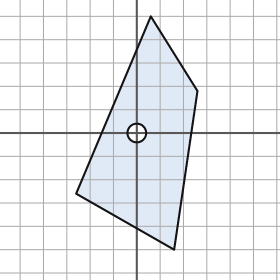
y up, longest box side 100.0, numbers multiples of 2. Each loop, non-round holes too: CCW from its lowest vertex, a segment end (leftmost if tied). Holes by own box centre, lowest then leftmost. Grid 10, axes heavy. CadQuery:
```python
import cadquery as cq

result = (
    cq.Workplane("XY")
    .moveTo(16.0, -50.0)
    .lineTo(26.0, 18.0)
    .lineTo(6.0, 50.0)
    .lineTo(-26.0, -26.0)
    .close()
    .moveTo(0.0, 0.0)
    .circle(4.0)
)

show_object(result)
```